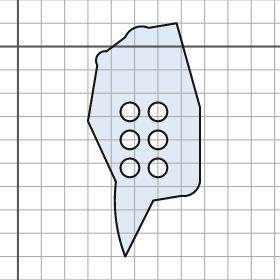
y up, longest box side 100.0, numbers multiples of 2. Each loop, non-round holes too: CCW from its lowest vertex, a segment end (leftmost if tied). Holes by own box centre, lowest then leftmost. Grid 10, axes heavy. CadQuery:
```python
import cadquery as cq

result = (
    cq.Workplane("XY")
    .moveTo(46.0, -90.0)
    .lineTo(58.0, -66.0)
    .lineTo(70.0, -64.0)
    .threePointArc((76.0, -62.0), (78.0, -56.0))
    .lineTo(78.0, -26.0)
    .lineTo(68.0, 10.0)
    .lineTo(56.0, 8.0)
    .threePointArc((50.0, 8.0), (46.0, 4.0))
    .lineTo(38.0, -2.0)
    .threePointArc((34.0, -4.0), (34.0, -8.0))
    .lineTo(30.0, -32.0)
    .lineTo(42.0, -58.0)
    .threePointArc((42.0, -74.0), (46.0, -90.0))
    .close()
    .moveTo(48.0, -52.0)
    .circle(4.0)
    .moveTo(60.0, -52.0)
    .circle(4.0)
    .moveTo(48.0, -40.0)
    .circle(4.0)
    .moveTo(60.0, -40.0)
    .circle(4.0)
    .moveTo(48.0, -28.0)
    .circle(4.0)
    .moveTo(60.0, -28.0)
    .circle(4.0)
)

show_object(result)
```